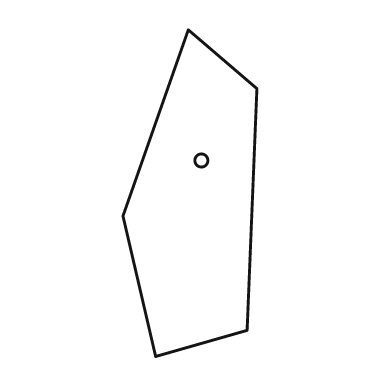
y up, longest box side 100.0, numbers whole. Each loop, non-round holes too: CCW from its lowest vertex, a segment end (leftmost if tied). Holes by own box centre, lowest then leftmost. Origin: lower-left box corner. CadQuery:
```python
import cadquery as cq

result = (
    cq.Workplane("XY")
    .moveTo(10.0, 0.0)
    .lineTo(38.0, 8.0)
    .lineTo(41.0, 82.0)
    .lineTo(20.0, 100.0)
    .lineTo(0.0, 43.0)
    .close()
    .moveTo(24.0, 60.0)
    .circle(2.0)
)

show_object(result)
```